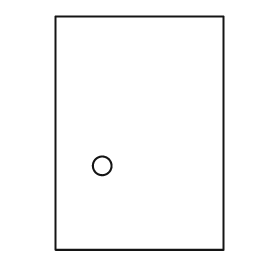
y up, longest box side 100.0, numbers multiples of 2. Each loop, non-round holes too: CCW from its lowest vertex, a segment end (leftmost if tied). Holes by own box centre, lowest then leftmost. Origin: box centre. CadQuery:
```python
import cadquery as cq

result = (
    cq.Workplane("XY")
    .moveTo(-36.0, -50.0)
    .lineTo(36.0, -50.0)
    .lineTo(36.0, 50.0)
    .lineTo(-36.0, 50.0)
    .close()
    .moveTo(-16.0, -14.0)
    .circle(4.0)
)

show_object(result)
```